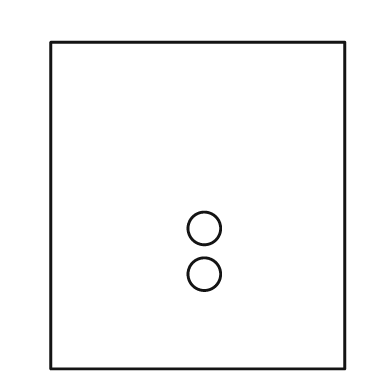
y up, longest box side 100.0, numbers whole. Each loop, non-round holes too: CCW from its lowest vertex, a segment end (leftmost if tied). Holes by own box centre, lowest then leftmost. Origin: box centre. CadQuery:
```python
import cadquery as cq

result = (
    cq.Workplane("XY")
    .moveTo(-45.0, -50.0)
    .lineTo(45.0, -50.0)
    .lineTo(45.0, 50.0)
    .lineTo(-45.0, 50.0)
    .close()
    .moveTo(2.0, -21.0)
    .circle(5.0)
    .moveTo(2.0, -7.0)
    .circle(5.0)
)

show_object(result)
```